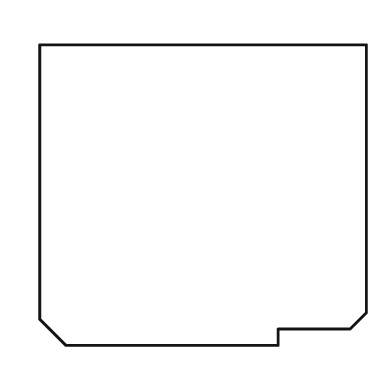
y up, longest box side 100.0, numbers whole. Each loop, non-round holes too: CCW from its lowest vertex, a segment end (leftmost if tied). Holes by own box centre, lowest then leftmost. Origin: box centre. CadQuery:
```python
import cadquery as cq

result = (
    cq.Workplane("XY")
    .moveTo(-42.0, -46.0)
    .lineTo(23.0, -46.0)
    .lineTo(23.0, -41.0)
    .lineTo(45.0, -41.0)
    .lineTo(50.0, -36.0)
    .lineTo(50.0, 46.0)
    .lineTo(-50.0, 46.0)
    .lineTo(-50.0, -38.0)
    .close()
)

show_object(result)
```